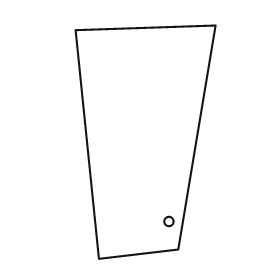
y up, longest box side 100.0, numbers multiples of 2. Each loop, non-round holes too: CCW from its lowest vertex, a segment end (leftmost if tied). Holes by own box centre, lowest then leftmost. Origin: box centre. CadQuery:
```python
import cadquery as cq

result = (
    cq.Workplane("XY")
    .moveTo(-20.0, -50.0)
    .lineTo(14.0, -46.0)
    .lineTo(30.0, 50.0)
    .lineTo(-30.0, 48.0)
    .close()
    .moveTo(10.0, -34.0)
    .circle(2.0)
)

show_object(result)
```